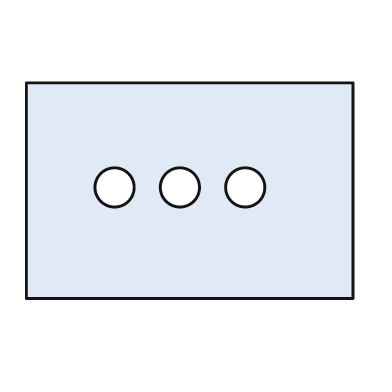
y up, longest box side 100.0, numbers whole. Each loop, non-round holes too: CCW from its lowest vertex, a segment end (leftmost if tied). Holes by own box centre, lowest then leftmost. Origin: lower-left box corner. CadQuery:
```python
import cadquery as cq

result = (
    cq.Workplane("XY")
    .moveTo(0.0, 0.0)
    .lineTo(100.0, 0.0)
    .lineTo(100.0, 66.0)
    .lineTo(0.0, 66.0)
    .close()
    .moveTo(27.0, 34.0)
    .circle(6.0)
    .moveTo(47.0, 34.0)
    .circle(6.0)
    .moveTo(67.0, 34.0)
    .circle(6.0)
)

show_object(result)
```